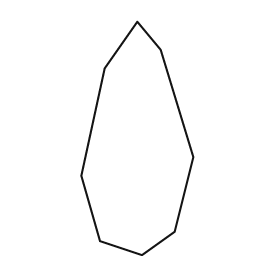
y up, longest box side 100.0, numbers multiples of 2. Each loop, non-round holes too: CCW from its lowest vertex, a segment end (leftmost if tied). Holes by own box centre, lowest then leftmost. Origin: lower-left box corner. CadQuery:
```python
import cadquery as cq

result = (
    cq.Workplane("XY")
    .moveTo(26.0, 0.0)
    .lineTo(40.0, 10.0)
    .lineTo(48.0, 42.0)
    .lineTo(34.0, 88.0)
    .lineTo(24.0, 100.0)
    .lineTo(10.0, 80.0)
    .lineTo(0.0, 34.0)
    .lineTo(8.0, 6.0)
    .close()
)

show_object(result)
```